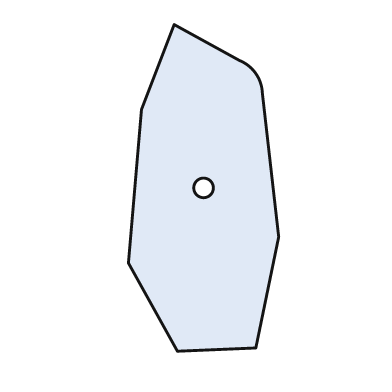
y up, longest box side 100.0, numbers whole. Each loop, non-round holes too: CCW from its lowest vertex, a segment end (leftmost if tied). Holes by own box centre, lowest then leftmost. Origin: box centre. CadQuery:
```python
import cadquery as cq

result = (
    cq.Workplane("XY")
    .moveTo(-8.0, -50.0)
    .lineTo(16.0, -49.0)
    .lineTo(23.0, -15.0)
    .lineTo(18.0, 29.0)
    .threePointArc((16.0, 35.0), (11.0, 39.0))
    .lineTo(-9.0, 50.0)
    .lineTo(-19.0, 24.0)
    .lineTo(-23.0, -23.0)
    .close()
    .moveTo(0.0, 0.0)
    .circle(3.0)
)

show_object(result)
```